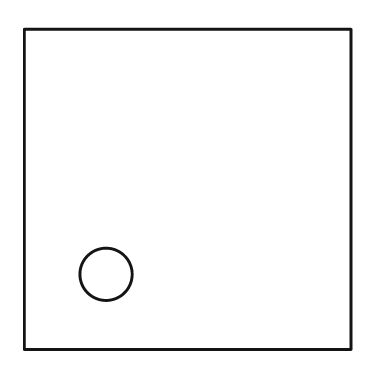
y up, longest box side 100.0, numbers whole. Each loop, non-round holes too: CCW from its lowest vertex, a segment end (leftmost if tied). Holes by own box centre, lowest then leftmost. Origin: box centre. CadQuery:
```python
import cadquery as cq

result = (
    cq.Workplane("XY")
    .moveTo(-50.0, -49.0)
    .lineTo(50.0, -49.0)
    .lineTo(50.0, 49.0)
    .lineTo(-50.0, 49.0)
    .close()
    .moveTo(-25.0, -26.0)
    .circle(8.0)
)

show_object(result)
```